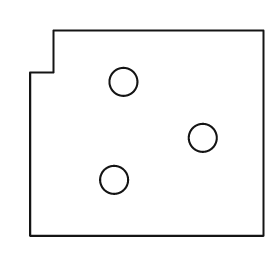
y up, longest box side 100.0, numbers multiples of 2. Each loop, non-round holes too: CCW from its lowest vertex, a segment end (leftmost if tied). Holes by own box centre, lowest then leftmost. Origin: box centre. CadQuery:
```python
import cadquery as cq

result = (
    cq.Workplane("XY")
    .moveTo(-50.0, -44.0)
    .lineTo(50.0, -44.0)
    .lineTo(50.0, 44.0)
    .lineTo(-40.0, 44.0)
    .lineTo(-40.0, 26.0)
    .lineTo(-50.0, 26.0)
    .close()
    .moveTo(-14.0, -20.0)
    .circle(6.0)
    .moveTo(24.0, -2.0)
    .circle(6.0)
    .moveTo(-10.0, 22.0)
    .circle(6.0)
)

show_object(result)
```